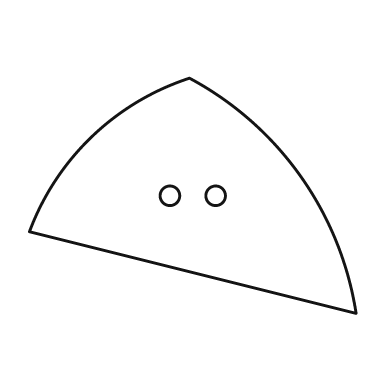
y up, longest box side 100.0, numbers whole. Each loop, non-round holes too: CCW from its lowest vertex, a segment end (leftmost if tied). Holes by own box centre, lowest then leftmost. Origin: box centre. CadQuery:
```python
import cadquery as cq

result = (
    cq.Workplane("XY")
    .moveTo(50.0, -36.0)
    .threePointArc((33.0, 6.0), (-1.0, 36.0))
    .threePointArc((-31.0, 18.0), (-50.0, -11.0))
    .close()
    .moveTo(-7.0, 0.0)
    .circle(3.0)
    .moveTo(7.0, 0.0)
    .circle(3.0)
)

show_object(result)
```